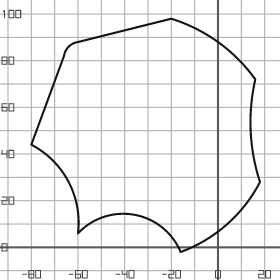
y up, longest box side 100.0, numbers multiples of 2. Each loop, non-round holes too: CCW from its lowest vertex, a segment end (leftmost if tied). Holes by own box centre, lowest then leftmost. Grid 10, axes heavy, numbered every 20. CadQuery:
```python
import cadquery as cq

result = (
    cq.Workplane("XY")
    .moveTo(-16.0, -2.0)
    .threePointArc((4.0, 10.0), (18.0, 28.0))
    .threePointArc((14.0, 50.0), (16.0, 72.0))
    .threePointArc((0.0, 88.0), (-20.0, 98.0))
    .lineTo(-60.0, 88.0)
    .threePointArc((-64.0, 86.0), (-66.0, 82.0))
    .lineTo(-80.0, 44.0)
    .threePointArc((-64.0, 28.0), (-60.0, 6.0))
    .threePointArc((-36.0, 14.0), (-16.0, -2.0))
    .close()
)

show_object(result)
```